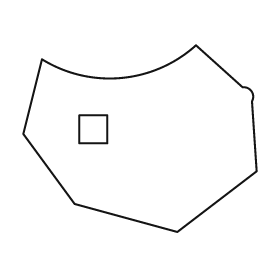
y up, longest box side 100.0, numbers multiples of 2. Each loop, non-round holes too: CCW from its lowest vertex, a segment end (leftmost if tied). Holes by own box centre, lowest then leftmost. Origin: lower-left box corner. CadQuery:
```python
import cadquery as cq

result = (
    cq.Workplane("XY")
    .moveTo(66.0, 0.0)
    .lineTo(100.0, 26.0)
    .lineTo(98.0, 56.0)
    .threePointArc((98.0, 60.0), (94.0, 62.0))
    .lineTo(74.0, 80.0)
    .threePointArc((42.0, 66.0), (8.0, 74.0))
    .lineTo(0.0, 42.0)
    .lineTo(22.0, 12.0)
    .close()
    .moveTo(24.0, 38.0)
    .lineTo(36.0, 38.0)
    .lineTo(36.0, 50.0)
    .lineTo(24.0, 50.0)
    .close()
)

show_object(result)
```